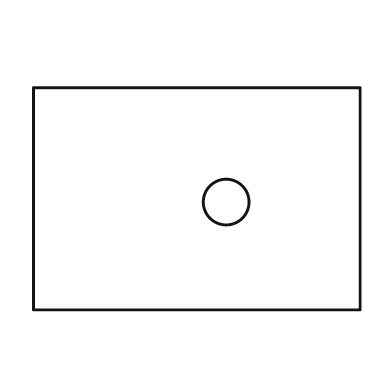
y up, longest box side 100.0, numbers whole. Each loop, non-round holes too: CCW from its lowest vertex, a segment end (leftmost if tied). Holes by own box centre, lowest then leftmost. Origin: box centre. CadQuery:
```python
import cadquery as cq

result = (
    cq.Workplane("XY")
    .moveTo(-50.0, -34.0)
    .lineTo(50.0, -34.0)
    .lineTo(50.0, 34.0)
    .lineTo(-50.0, 34.0)
    .close()
    .moveTo(9.0, -1.0)
    .circle(7.0)
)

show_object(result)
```